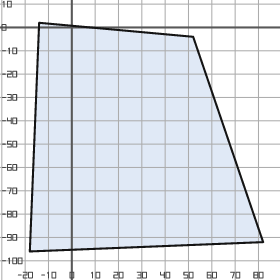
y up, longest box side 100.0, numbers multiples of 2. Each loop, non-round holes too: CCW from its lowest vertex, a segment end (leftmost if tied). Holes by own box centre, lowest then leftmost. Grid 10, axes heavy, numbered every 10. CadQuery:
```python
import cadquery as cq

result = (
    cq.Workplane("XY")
    .moveTo(-18.0, -96.0)
    .lineTo(82.0, -92.0)
    .lineTo(52.0, -4.0)
    .lineTo(-14.0, 2.0)
    .close()
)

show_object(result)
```